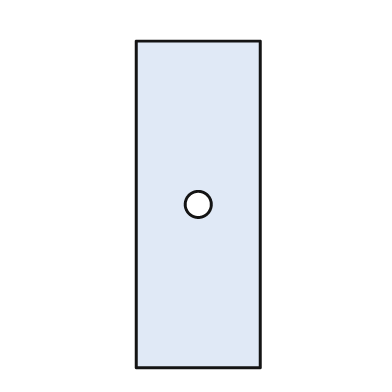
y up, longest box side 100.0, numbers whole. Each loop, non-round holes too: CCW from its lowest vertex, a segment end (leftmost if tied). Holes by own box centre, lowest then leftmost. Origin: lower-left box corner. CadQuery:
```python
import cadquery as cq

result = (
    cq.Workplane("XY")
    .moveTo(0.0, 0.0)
    .lineTo(38.0, 0.0)
    .lineTo(38.0, 100.0)
    .lineTo(0.0, 100.0)
    .close()
    .moveTo(19.0, 50.0)
    .circle(4.0)
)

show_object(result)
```